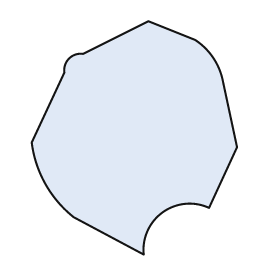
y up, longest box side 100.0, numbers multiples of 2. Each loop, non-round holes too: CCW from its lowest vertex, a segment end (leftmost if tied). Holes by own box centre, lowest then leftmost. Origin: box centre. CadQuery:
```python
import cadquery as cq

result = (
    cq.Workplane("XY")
    .moveTo(4.0, -50.0)
    .threePointArc((12.0, -32.0), (32.0, -30.0))
    .lineTo(44.0, -4.0)
    .lineTo(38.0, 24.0)
    .threePointArc((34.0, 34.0), (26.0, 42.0))
    .lineTo(6.0, 50.0)
    .lineTo(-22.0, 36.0)
    .threePointArc((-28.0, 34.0), (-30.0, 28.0))
    .lineTo(-44.0, -2.0)
    .threePointArc((-38.0, -20.0), (-26.0, -34.0))
    .close()
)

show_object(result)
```